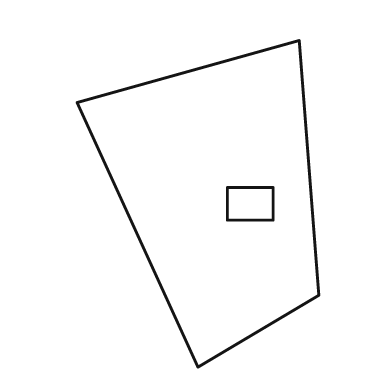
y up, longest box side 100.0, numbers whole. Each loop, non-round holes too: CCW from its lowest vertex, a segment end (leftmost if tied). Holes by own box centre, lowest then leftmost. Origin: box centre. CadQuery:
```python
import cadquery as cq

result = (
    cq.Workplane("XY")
    .moveTo(0.0, -50.0)
    .lineTo(37.0, -28.0)
    .lineTo(31.0, 50.0)
    .lineTo(-37.0, 31.0)
    .close()
    .moveTo(9.0, -5.0)
    .lineTo(23.0, -5.0)
    .lineTo(23.0, 5.0)
    .lineTo(9.0, 5.0)
    .close()
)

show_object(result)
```